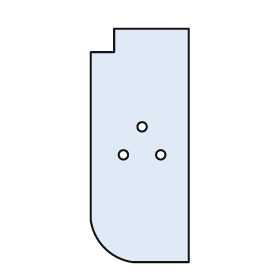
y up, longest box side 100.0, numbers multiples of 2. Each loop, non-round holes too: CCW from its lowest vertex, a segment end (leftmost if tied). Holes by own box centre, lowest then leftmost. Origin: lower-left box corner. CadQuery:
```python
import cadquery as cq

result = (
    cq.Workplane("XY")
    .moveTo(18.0, 0.0)
    .lineTo(42.0, 0.0)
    .lineTo(42.0, 100.0)
    .lineTo(10.0, 100.0)
    .lineTo(10.0, 90.0)
    .lineTo(0.0, 90.0)
    .lineTo(0.0, 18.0)
    .threePointArc((6.0, 6.0), (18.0, 0.0))
    .close()
    .moveTo(14.0, 46.0)
    .circle(2.0)
    .moveTo(30.0, 46.0)
    .circle(2.0)
    .moveTo(22.0, 58.0)
    .circle(2.0)
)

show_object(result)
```